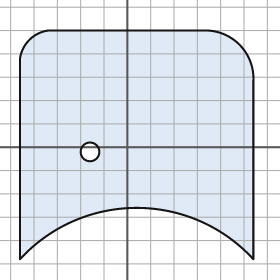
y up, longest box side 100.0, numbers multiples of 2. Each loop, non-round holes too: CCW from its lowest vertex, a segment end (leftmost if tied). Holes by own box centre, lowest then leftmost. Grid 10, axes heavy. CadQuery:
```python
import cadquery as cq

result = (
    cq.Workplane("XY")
    .moveTo(-46.0, -48.0)
    .threePointArc((4.0, -26.0), (54.0, -48.0))
    .lineTo(54.0, 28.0)
    .threePointArc((48.0, 44.0), (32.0, 50.0))
    .lineTo(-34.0, 50.0)
    .threePointArc((-42.0, 46.0), (-46.0, 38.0))
    .close()
    .moveTo(-16.0, -2.0)
    .circle(4.0)
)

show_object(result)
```